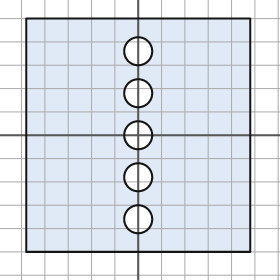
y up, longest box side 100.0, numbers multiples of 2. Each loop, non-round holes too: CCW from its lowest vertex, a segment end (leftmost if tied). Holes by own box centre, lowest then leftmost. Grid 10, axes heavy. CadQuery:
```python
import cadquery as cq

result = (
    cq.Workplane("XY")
    .moveTo(-48.0, -50.0)
    .lineTo(48.0, -50.0)
    .lineTo(48.0, 50.0)
    .lineTo(-48.0, 50.0)
    .close()
    .moveTo(0.0, -36.0)
    .circle(6.0)
    .moveTo(0.0, -18.0)
    .circle(6.0)
    .moveTo(0.0, 0.0)
    .circle(6.0)
    .moveTo(0.0, 18.0)
    .circle(6.0)
    .moveTo(0.0, 36.0)
    .circle(6.0)
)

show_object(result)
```